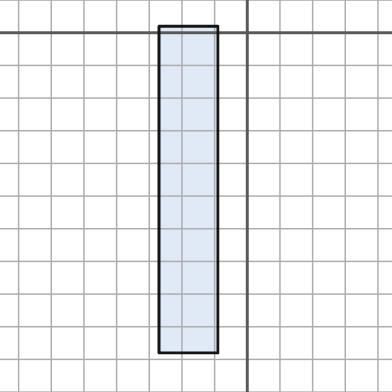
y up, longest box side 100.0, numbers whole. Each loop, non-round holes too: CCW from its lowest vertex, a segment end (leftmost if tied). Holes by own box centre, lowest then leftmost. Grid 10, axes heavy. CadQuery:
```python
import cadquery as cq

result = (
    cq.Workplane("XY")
    .moveTo(-27.0, -98.0)
    .lineTo(-9.0, -98.0)
    .lineTo(-9.0, 2.0)
    .lineTo(-27.0, 2.0)
    .close()
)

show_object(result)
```